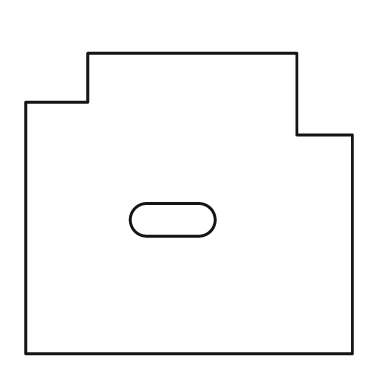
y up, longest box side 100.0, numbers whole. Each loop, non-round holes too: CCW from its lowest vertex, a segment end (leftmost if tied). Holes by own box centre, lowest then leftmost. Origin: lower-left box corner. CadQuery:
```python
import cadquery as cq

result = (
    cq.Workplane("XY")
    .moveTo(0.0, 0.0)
    .lineTo(100.0, 0.0)
    .lineTo(100.0, 67.0)
    .lineTo(83.0, 67.0)
    .lineTo(83.0, 92.0)
    .lineTo(19.0, 92.0)
    .lineTo(19.0, 77.0)
    .lineTo(0.0, 77.0)
    .close()
    .moveTo(37.0, 36.0)
    .lineTo(53.0, 36.0)
    .threePointArc((58.0, 41.0), (53.0, 46.0))
    .lineTo(37.0, 46.0)
    .threePointArc((32.0, 41.0), (37.0, 36.0))
    .close()
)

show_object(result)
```